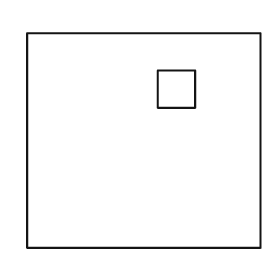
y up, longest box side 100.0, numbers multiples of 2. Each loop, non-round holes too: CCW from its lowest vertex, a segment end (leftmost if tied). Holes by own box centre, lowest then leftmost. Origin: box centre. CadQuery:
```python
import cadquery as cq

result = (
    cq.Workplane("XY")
    .moveTo(-50.0, -46.0)
    .lineTo(50.0, -46.0)
    .lineTo(50.0, 46.0)
    .lineTo(-50.0, 46.0)
    .close()
    .moveTo(6.0, 14.0)
    .lineTo(22.0, 14.0)
    .lineTo(22.0, 30.0)
    .lineTo(6.0, 30.0)
    .close()
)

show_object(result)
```